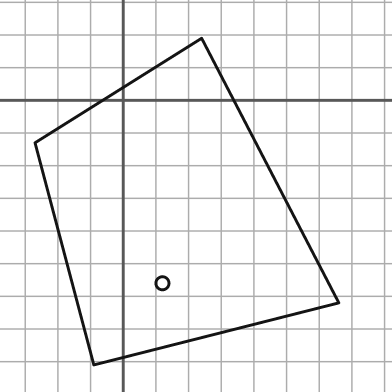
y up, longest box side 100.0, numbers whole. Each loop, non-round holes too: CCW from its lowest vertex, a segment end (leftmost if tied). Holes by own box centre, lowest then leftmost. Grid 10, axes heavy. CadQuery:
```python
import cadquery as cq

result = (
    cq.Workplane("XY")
    .moveTo(-9.0, -81.0)
    .lineTo(66.0, -62.0)
    .lineTo(24.0, 19.0)
    .lineTo(-27.0, -13.0)
    .close()
    .moveTo(12.0, -56.0)
    .circle(2.0)
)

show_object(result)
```